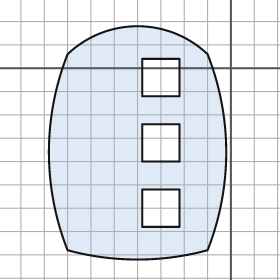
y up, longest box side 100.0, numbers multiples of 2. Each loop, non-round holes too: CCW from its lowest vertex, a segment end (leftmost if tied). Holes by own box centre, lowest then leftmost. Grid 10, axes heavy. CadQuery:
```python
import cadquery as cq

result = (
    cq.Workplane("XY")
    .moveTo(-70.0, -78.0)
    .threePointArc((-40.0, -82.0), (-10.0, -78.0))
    .threePointArc((-2.0, -36.0), (-10.0, 6.0))
    .threePointArc((-40.0, 18.0), (-70.0, 6.0))
    .threePointArc((-78.0, -36.0), (-70.0, -78.0))
    .close()
    .moveTo(-38.0, -68.0)
    .lineTo(-22.0, -68.0)
    .lineTo(-22.0, -52.0)
    .lineTo(-38.0, -52.0)
    .close()
    .moveTo(-38.0, -40.0)
    .lineTo(-22.0, -40.0)
    .lineTo(-22.0, -24.0)
    .lineTo(-38.0, -24.0)
    .close()
    .moveTo(-38.0, -12.0)
    .lineTo(-22.0, -12.0)
    .lineTo(-22.0, 4.0)
    .lineTo(-38.0, 4.0)
    .close()
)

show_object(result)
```